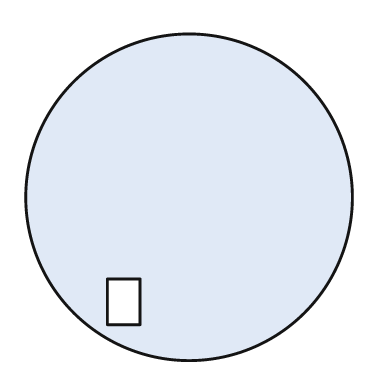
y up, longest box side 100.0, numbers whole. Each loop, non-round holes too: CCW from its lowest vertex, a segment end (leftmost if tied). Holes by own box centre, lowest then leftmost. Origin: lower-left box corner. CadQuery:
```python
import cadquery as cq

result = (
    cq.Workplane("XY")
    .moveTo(50.0, 50.0)
    .circle(50.0)
    .moveTo(25.0, 11.0)
    .lineTo(35.0, 11.0)
    .lineTo(35.0, 25.0)
    .lineTo(25.0, 25.0)
    .close()
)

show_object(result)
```